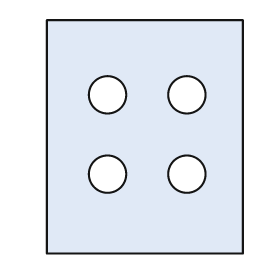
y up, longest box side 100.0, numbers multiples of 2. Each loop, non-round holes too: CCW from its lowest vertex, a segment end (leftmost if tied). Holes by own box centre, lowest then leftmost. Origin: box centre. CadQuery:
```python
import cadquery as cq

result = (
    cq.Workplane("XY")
    .moveTo(-42.0, -50.0)
    .lineTo(42.0, -50.0)
    .lineTo(42.0, 50.0)
    .lineTo(-42.0, 50.0)
    .close()
    .moveTo(-16.0, -16.0)
    .circle(8.0)
    .moveTo(18.0, -16.0)
    .circle(8.0)
    .moveTo(-16.0, 18.0)
    .circle(8.0)
    .moveTo(18.0, 18.0)
    .circle(8.0)
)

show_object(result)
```